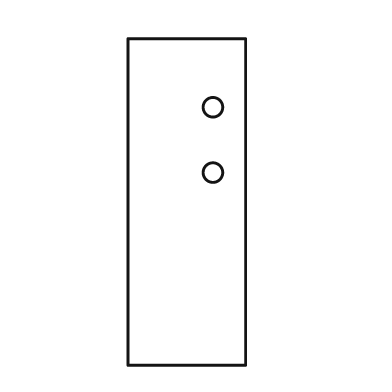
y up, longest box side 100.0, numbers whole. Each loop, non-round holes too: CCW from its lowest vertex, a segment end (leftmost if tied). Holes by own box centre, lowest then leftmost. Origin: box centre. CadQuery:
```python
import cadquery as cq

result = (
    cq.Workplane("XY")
    .moveTo(-18.0, -50.0)
    .lineTo(18.0, -50.0)
    .lineTo(18.0, 50.0)
    .lineTo(-18.0, 50.0)
    .close()
    .moveTo(8.0, 9.0)
    .circle(3.0)
    .moveTo(8.0, 29.0)
    .circle(3.0)
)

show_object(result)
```